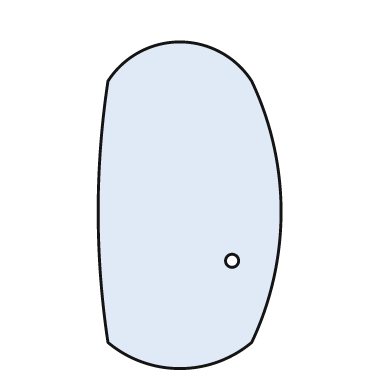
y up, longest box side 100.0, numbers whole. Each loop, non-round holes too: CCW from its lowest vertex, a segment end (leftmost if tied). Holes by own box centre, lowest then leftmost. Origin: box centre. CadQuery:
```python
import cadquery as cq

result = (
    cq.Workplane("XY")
    .moveTo(-25.0, -42.0)
    .threePointArc((-3.0, -50.0), (19.0, -42.0))
    .threePointArc((28.0, -2.0), (19.0, 38.0))
    .threePointArc((-3.0, 50.0), (-25.0, 38.0))
    .threePointArc((-28.0, -2.0), (-25.0, -42.0))
    .close()
    .moveTo(13.0, -17.0)
    .circle(2.0)
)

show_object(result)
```